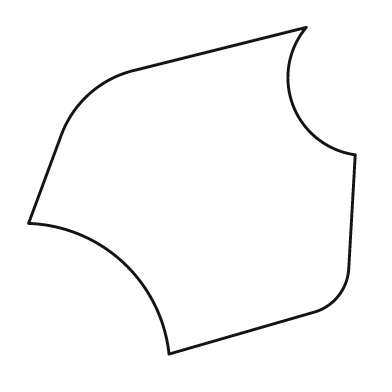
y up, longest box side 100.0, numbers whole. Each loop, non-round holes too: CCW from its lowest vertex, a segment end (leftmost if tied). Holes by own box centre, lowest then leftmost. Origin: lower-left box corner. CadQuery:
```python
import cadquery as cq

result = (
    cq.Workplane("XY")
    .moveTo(43.0, 0.0)
    .lineTo(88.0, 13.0)
    .threePointArc((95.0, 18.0), (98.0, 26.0))
    .lineTo(100.0, 61.0)
    .threePointArc((81.0, 76.0), (85.0, 100.0))
    .lineTo(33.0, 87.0)
    .threePointArc((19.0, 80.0), (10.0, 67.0))
    .lineTo(0.0, 40.0)
    .threePointArc((29.0, 28.0), (43.0, 0.0))
    .close()
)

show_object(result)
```